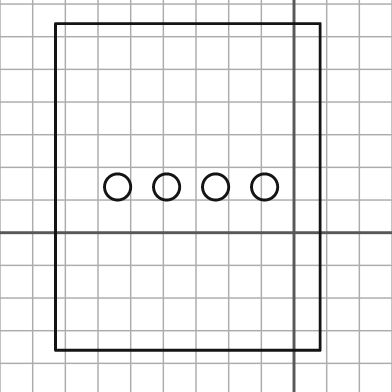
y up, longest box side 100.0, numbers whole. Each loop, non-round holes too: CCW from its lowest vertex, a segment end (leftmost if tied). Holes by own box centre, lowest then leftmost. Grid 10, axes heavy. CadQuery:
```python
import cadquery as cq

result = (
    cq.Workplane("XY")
    .moveTo(-73.0, -36.0)
    .lineTo(8.0, -36.0)
    .lineTo(8.0, 64.0)
    .lineTo(-73.0, 64.0)
    .close()
    .moveTo(-54.0, 14.0)
    .circle(4.0)
    .moveTo(-39.0, 14.0)
    .circle(4.0)
    .moveTo(-24.0, 14.0)
    .circle(4.0)
    .moveTo(-9.0, 14.0)
    .circle(4.0)
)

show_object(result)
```